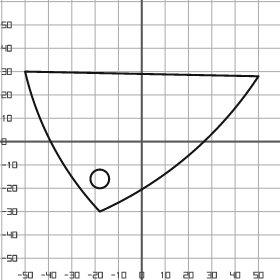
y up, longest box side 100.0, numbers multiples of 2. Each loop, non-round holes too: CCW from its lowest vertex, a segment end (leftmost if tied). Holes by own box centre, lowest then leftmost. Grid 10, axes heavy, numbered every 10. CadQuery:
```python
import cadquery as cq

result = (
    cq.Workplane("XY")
    .moveTo(-18.0, -30.0)
    .threePointArc((20.0, -6.0), (50.0, 28.0))
    .lineTo(-50.0, 30.0)
    .threePointArc((-38.0, -2.0), (-18.0, -30.0))
    .close()
    .moveTo(-18.0, -16.0)
    .circle(4.0)
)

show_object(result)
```